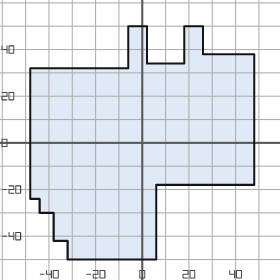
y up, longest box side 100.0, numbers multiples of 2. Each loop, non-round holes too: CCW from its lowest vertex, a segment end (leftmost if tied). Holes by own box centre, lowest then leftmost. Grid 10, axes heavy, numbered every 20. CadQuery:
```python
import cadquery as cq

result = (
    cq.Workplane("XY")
    .moveTo(-32.0, -50.0)
    .lineTo(6.0, -50.0)
    .lineTo(6.0, -18.0)
    .lineTo(48.0, -18.0)
    .lineTo(48.0, 38.0)
    .lineTo(26.0, 38.0)
    .lineTo(26.0, 50.0)
    .lineTo(18.0, 50.0)
    .lineTo(18.0, 34.0)
    .lineTo(2.0, 34.0)
    .lineTo(2.0, 50.0)
    .lineTo(-6.0, 50.0)
    .lineTo(-6.0, 32.0)
    .lineTo(-48.0, 32.0)
    .lineTo(-48.0, -24.0)
    .lineTo(-44.0, -24.0)
    .lineTo(-44.0, -30.0)
    .lineTo(-38.0, -30.0)
    .lineTo(-38.0, -42.0)
    .lineTo(-32.0, -42.0)
    .close()
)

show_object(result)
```